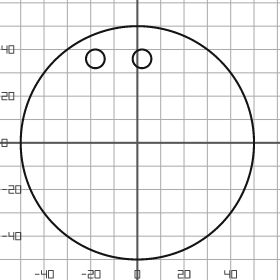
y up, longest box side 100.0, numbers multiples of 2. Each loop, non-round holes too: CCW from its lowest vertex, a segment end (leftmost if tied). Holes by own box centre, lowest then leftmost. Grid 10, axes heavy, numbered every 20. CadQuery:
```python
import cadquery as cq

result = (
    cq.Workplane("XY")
    .moveTo(0.0, 0.0)
    .circle(50.0)
    .moveTo(-18.0, 36.0)
    .circle(4.0)
    .moveTo(2.0, 36.0)
    .circle(4.0)
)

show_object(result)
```